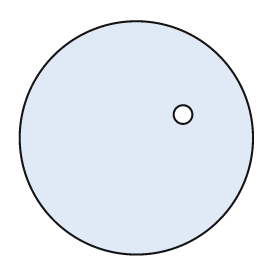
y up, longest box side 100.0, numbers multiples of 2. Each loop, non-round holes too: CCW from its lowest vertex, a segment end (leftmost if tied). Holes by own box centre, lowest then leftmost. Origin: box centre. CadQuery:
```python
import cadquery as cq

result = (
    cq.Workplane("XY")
    .moveTo(0.0, 0.0)
    .circle(50.0)
    .moveTo(20.0, 10.0)
    .circle(4.0)
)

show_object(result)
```